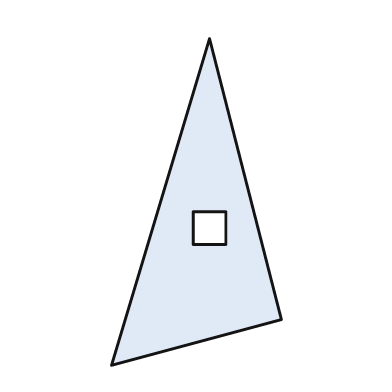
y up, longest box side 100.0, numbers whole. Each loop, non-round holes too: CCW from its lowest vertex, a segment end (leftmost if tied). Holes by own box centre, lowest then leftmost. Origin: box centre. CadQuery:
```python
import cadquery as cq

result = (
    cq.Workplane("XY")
    .moveTo(-26.0, -50.0)
    .lineTo(26.0, -36.0)
    .lineTo(4.0, 50.0)
    .close()
    .moveTo(-1.0, -13.0)
    .lineTo(9.0, -13.0)
    .lineTo(9.0, -3.0)
    .lineTo(-1.0, -3.0)
    .close()
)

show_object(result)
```